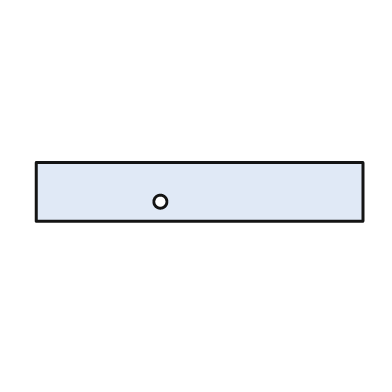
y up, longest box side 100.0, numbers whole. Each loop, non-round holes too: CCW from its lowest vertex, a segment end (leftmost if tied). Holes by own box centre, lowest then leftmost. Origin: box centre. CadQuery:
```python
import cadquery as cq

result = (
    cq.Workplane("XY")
    .moveTo(-50.0, -9.0)
    .lineTo(50.0, -9.0)
    .lineTo(50.0, 9.0)
    .lineTo(-50.0, 9.0)
    .close()
    .moveTo(-12.0, -3.0)
    .circle(2.0)
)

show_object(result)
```